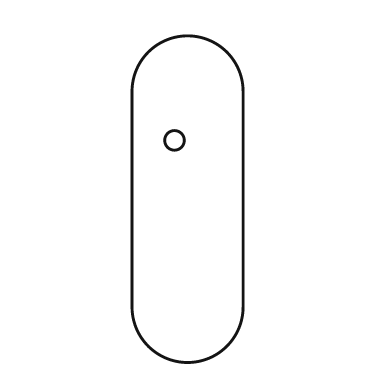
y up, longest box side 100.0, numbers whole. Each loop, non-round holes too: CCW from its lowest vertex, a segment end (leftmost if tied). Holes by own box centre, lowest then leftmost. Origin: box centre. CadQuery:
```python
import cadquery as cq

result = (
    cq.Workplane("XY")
    .moveTo(-17.0, -33.0)
    .threePointArc((0.0, -50.0), (17.0, -33.0))
    .lineTo(17.0, 33.0)
    .threePointArc((0.0, 50.0), (-17.0, 33.0))
    .close()
    .moveTo(-4.0, 18.0)
    .circle(3.0)
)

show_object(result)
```